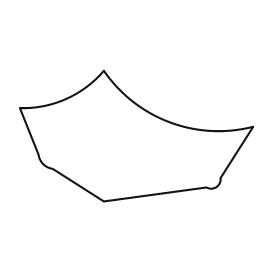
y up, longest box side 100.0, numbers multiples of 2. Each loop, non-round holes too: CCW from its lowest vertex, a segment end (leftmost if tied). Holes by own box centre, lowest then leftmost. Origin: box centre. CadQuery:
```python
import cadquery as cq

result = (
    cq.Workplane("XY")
    .moveTo(-14.0, -28.0)
    .lineTo(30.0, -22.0)
    .threePointArc((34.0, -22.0), (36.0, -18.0))
    .lineTo(50.0, 4.0)
    .threePointArc((14.0, 6.0), (-14.0, 28.0))
    .threePointArc((-30.0, 16.0), (-50.0, 12.0))
    .lineTo(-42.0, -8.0)
    .threePointArc((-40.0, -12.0), (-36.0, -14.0))
    .close()
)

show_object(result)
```